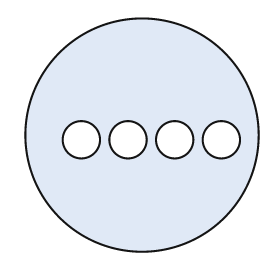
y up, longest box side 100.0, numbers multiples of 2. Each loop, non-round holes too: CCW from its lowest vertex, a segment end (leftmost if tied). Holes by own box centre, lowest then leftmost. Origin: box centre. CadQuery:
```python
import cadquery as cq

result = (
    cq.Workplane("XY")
    .moveTo(0.0, 0.0)
    .circle(50.0)
    .moveTo(-26.0, -2.0)
    .circle(8.0)
    .moveTo(-6.0, -2.0)
    .circle(8.0)
    .moveTo(14.0, -2.0)
    .circle(8.0)
    .moveTo(34.0, -2.0)
    .circle(8.0)
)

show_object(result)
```